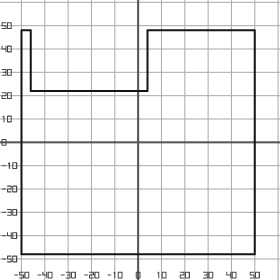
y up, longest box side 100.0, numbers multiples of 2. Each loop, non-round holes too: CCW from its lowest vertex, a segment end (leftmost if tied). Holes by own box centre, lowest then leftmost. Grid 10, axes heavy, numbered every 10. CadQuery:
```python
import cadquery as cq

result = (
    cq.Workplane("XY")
    .moveTo(-50.0, -48.0)
    .lineTo(50.0, -48.0)
    .lineTo(50.0, 48.0)
    .lineTo(4.0, 48.0)
    .lineTo(4.0, 22.0)
    .lineTo(-46.0, 22.0)
    .lineTo(-46.0, 48.0)
    .lineTo(-50.0, 48.0)
    .close()
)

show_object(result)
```